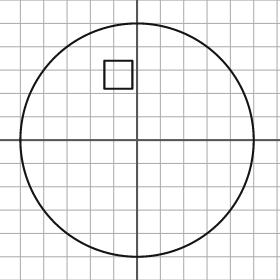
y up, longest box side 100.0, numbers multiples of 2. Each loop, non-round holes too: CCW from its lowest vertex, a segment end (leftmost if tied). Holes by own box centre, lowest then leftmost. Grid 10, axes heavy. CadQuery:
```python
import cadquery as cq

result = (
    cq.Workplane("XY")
    .moveTo(0.0, 0.0)
    .circle(50.0)
    .moveTo(-14.0, 22.0)
    .lineTo(-2.0, 22.0)
    .lineTo(-2.0, 34.0)
    .lineTo(-14.0, 34.0)
    .close()
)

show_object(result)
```